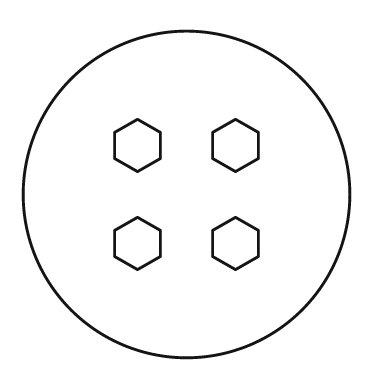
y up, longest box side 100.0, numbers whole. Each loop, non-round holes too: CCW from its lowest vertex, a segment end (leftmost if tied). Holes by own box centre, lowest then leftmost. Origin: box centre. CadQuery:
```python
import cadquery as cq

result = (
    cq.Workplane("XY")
    .moveTo(0.0, 0.0)
    .circle(50.0)
    .moveTo(-15.0, -23.0)
    .lineTo(-8.0, -19.0)
    .lineTo(-8.0, -11.0)
    .lineTo(-15.0, -7.0)
    .lineTo(-22.0, -11.0)
    .lineTo(-22.0, -19.0)
    .close()
    .moveTo(15.0, -23.0)
    .lineTo(22.0, -19.0)
    .lineTo(22.0, -11.0)
    .lineTo(15.0, -7.0)
    .lineTo(8.0, -11.0)
    .lineTo(8.0, -19.0)
    .close()
    .moveTo(-15.0, 7.0)
    .lineTo(-8.0, 11.0)
    .lineTo(-8.0, 19.0)
    .lineTo(-15.0, 23.0)
    .lineTo(-22.0, 19.0)
    .lineTo(-22.0, 11.0)
    .close()
    .moveTo(15.0, 7.0)
    .lineTo(22.0, 11.0)
    .lineTo(22.0, 19.0)
    .lineTo(15.0, 23.0)
    .lineTo(8.0, 19.0)
    .lineTo(8.0, 11.0)
    .close()
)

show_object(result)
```